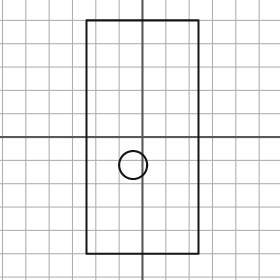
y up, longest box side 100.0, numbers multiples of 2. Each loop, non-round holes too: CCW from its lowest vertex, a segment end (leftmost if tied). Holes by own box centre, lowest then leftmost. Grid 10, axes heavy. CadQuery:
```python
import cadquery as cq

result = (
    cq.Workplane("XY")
    .moveTo(-24.0, -50.0)
    .lineTo(24.0, -50.0)
    .lineTo(24.0, 50.0)
    .lineTo(-24.0, 50.0)
    .close()
    .moveTo(-4.0, -12.0)
    .circle(6.0)
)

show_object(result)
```